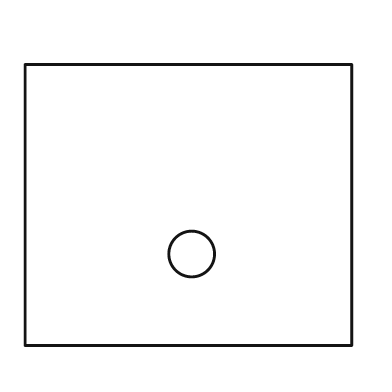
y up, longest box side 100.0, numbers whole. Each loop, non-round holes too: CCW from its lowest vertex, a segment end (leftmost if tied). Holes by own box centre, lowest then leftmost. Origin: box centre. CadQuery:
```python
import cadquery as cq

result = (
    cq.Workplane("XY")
    .moveTo(-50.0, -43.0)
    .lineTo(50.0, -43.0)
    .lineTo(50.0, 43.0)
    .lineTo(-50.0, 43.0)
    .close()
    .moveTo(1.0, -15.0)
    .circle(7.0)
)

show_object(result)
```